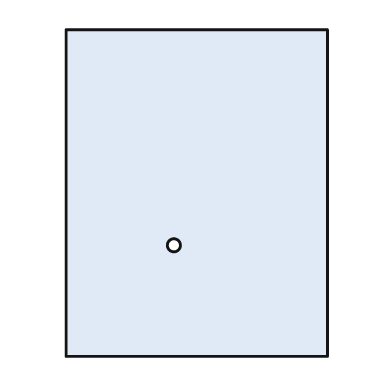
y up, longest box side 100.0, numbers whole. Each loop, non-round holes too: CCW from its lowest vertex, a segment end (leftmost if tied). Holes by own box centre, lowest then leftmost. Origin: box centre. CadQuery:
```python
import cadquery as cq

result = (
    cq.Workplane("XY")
    .moveTo(-40.0, -50.0)
    .lineTo(40.0, -50.0)
    .lineTo(40.0, 50.0)
    .lineTo(-40.0, 50.0)
    .close()
    .moveTo(-7.0, -16.0)
    .circle(2.0)
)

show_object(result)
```